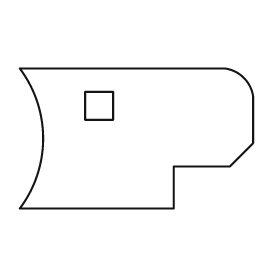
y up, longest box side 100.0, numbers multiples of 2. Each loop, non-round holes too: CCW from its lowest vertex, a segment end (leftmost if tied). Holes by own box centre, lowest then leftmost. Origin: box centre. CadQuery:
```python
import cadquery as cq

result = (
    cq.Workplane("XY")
    .moveTo(-50.0, -30.0)
    .lineTo(16.0, -30.0)
    .lineTo(16.0, -12.0)
    .lineTo(40.0, -12.0)
    .lineTo(50.0, -2.0)
    .lineTo(50.0, 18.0)
    .threePointArc((46.0, 26.0), (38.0, 30.0))
    .lineTo(-50.0, 30.0)
    .threePointArc((-40.0, 0.0), (-50.0, -30.0))
    .close()
    .moveTo(-22.0, 8.0)
    .lineTo(-10.0, 8.0)
    .lineTo(-10.0, 20.0)
    .lineTo(-22.0, 20.0)
    .close()
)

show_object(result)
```